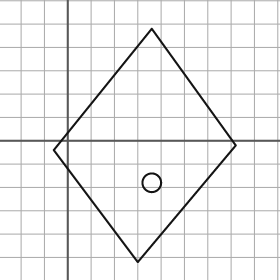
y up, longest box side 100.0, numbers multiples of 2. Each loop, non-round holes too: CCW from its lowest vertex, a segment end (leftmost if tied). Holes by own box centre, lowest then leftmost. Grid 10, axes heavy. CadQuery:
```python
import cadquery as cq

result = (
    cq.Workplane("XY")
    .moveTo(30.0, -52.0)
    .lineTo(72.0, -2.0)
    .lineTo(36.0, 48.0)
    .lineTo(-6.0, -4.0)
    .close()
    .moveTo(36.0, -18.0)
    .circle(4.0)
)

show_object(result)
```